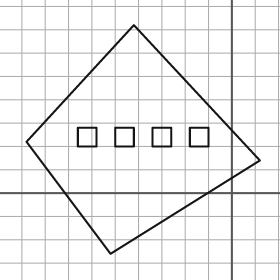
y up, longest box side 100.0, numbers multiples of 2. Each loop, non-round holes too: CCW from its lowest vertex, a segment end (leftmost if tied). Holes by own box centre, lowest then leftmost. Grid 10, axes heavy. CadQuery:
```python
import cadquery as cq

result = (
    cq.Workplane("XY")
    .moveTo(-52.0, -26.0)
    .lineTo(12.0, 14.0)
    .lineTo(-42.0, 72.0)
    .lineTo(-88.0, 22.0)
    .close()
    .moveTo(-66.0, 20.0)
    .lineTo(-58.0, 20.0)
    .lineTo(-58.0, 28.0)
    .lineTo(-66.0, 28.0)
    .close()
    .moveTo(-50.0, 20.0)
    .lineTo(-42.0, 20.0)
    .lineTo(-42.0, 28.0)
    .lineTo(-50.0, 28.0)
    .close()
    .moveTo(-34.0, 20.0)
    .lineTo(-26.0, 20.0)
    .lineTo(-26.0, 28.0)
    .lineTo(-34.0, 28.0)
    .close()
    .moveTo(-18.0, 20.0)
    .lineTo(-10.0, 20.0)
    .lineTo(-10.0, 28.0)
    .lineTo(-18.0, 28.0)
    .close()
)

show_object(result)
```